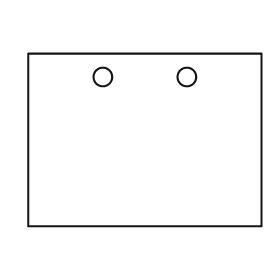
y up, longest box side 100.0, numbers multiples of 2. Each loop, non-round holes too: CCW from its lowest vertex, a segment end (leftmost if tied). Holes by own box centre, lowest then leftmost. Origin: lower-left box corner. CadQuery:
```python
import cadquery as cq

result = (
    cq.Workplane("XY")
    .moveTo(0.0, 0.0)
    .lineTo(100.0, 0.0)
    .lineTo(100.0, 74.0)
    .lineTo(0.0, 74.0)
    .close()
    .moveTo(32.0, 64.0)
    .circle(4.0)
    .moveTo(68.0, 64.0)
    .circle(4.0)
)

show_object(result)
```